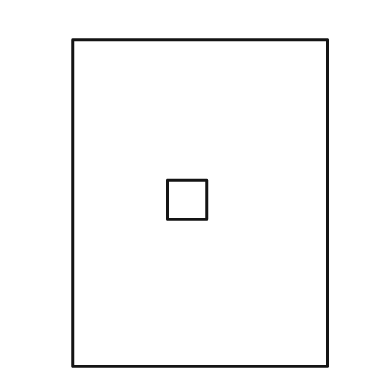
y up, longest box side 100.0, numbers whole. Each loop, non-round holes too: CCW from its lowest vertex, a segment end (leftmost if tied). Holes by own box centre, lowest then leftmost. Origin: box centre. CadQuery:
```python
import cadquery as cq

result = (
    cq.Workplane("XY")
    .moveTo(-39.0, -50.0)
    .lineTo(39.0, -50.0)
    .lineTo(39.0, 50.0)
    .lineTo(-39.0, 50.0)
    .close()
    .moveTo(-10.0, -5.0)
    .lineTo(2.0, -5.0)
    .lineTo(2.0, 7.0)
    .lineTo(-10.0, 7.0)
    .close()
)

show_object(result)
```